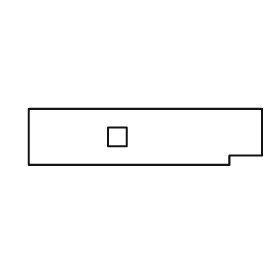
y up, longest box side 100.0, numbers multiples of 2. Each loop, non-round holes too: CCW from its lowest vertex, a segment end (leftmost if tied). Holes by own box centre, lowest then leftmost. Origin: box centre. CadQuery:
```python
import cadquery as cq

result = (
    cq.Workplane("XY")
    .moveTo(-50.0, -12.0)
    .lineTo(36.0, -12.0)
    .lineTo(36.0, -8.0)
    .lineTo(50.0, -8.0)
    .lineTo(50.0, 12.0)
    .lineTo(-50.0, 12.0)
    .close()
    .moveTo(-16.0, -4.0)
    .lineTo(-8.0, -4.0)
    .lineTo(-8.0, 4.0)
    .lineTo(-16.0, 4.0)
    .close()
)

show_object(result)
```